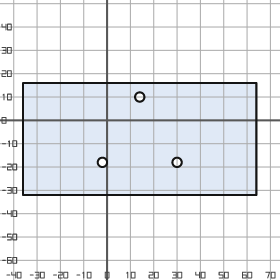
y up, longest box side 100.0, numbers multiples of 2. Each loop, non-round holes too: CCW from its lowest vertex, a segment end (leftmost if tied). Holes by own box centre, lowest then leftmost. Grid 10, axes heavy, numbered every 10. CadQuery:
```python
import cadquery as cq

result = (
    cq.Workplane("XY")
    .moveTo(-36.0, -32.0)
    .lineTo(64.0, -32.0)
    .lineTo(64.0, 16.0)
    .lineTo(-36.0, 16.0)
    .close()
    .moveTo(-2.0, -18.0)
    .circle(2.0)
    .moveTo(30.0, -18.0)
    .circle(2.0)
    .moveTo(14.0, 10.0)
    .circle(2.0)
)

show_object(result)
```